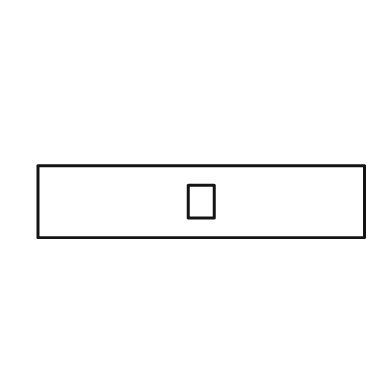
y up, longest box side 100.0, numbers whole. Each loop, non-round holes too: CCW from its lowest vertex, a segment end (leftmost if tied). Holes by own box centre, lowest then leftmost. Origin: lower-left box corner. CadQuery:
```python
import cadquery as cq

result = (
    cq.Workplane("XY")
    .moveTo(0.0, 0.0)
    .lineTo(100.0, 0.0)
    .lineTo(100.0, 22.0)
    .lineTo(0.0, 22.0)
    .close()
    .moveTo(46.0, 6.0)
    .lineTo(54.0, 6.0)
    .lineTo(54.0, 16.0)
    .lineTo(46.0, 16.0)
    .close()
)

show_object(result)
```